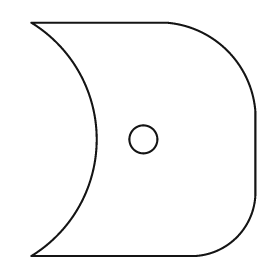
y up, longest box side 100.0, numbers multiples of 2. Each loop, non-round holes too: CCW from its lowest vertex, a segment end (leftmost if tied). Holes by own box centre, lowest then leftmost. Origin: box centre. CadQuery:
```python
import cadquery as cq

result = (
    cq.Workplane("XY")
    .moveTo(-48.0, -50.0)
    .lineTo(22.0, -50.0)
    .threePointArc((40.0, -42.0), (48.0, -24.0))
    .lineTo(48.0, 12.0)
    .threePointArc((36.0, 38.0), (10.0, 50.0))
    .lineTo(-48.0, 50.0)
    .threePointArc((-20.0, 0.0), (-48.0, -50.0))
    .close()
    .moveTo(0.0, 0.0)
    .circle(6.0)
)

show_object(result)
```